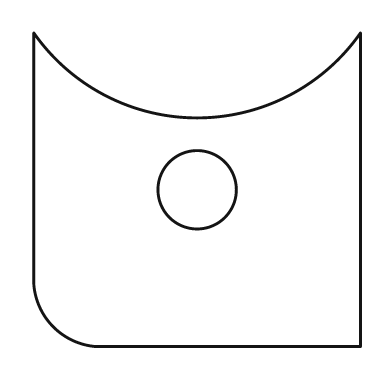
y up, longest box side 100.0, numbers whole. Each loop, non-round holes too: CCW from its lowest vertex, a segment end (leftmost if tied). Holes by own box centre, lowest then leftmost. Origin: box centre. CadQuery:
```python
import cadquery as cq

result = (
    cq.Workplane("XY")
    .moveTo(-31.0, -48.0)
    .lineTo(50.0, -48.0)
    .lineTo(50.0, 48.0)
    .threePointArc((0.0, 22.0), (-50.0, 48.0))
    .lineTo(-50.0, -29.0)
    .threePointArc((-44.0, -42.0), (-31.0, -48.0))
    .close()
    .moveTo(0.0, 0.0)
    .circle(12.0)
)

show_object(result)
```